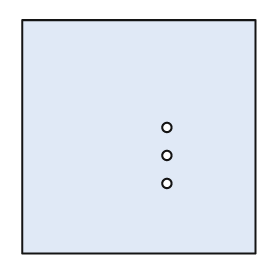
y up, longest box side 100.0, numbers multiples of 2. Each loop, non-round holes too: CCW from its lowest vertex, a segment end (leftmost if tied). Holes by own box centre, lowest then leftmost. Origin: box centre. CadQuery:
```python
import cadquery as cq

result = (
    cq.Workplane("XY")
    .moveTo(-50.0, -50.0)
    .lineTo(50.0, -50.0)
    .lineTo(50.0, 50.0)
    .lineTo(-50.0, 50.0)
    .close()
    .moveTo(12.0, -20.0)
    .circle(2.0)
    .moveTo(12.0, -8.0)
    .circle(2.0)
    .moveTo(12.0, 4.0)
    .circle(2.0)
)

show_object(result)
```